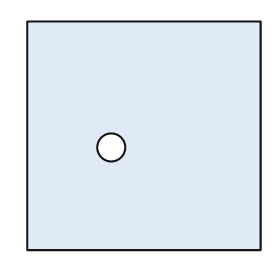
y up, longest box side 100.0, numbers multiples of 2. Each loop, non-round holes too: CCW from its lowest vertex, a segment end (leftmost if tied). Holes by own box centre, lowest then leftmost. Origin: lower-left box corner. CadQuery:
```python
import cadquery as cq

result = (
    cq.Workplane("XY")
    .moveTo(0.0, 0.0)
    .lineTo(100.0, 0.0)
    .lineTo(100.0, 98.0)
    .lineTo(0.0, 98.0)
    .close()
    .moveTo(36.0, 44.0)
    .circle(6.0)
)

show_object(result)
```